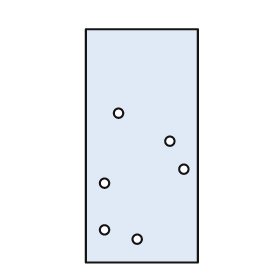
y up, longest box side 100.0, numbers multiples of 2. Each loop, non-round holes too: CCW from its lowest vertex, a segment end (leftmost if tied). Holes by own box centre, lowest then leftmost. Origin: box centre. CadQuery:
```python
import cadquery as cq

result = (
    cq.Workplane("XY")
    .moveTo(-24.0, -50.0)
    .lineTo(24.0, -50.0)
    .lineTo(24.0, 50.0)
    .lineTo(-24.0, 50.0)
    .close()
    .moveTo(-2.0, -40.0)
    .circle(2.0)
    .moveTo(-16.0, -36.0)
    .circle(2.0)
    .moveTo(-16.0, -16.0)
    .circle(2.0)
    .moveTo(18.0, -10.0)
    .circle(2.0)
    .moveTo(12.0, 2.0)
    .circle(2.0)
    .moveTo(-10.0, 14.0)
    .circle(2.0)
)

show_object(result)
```